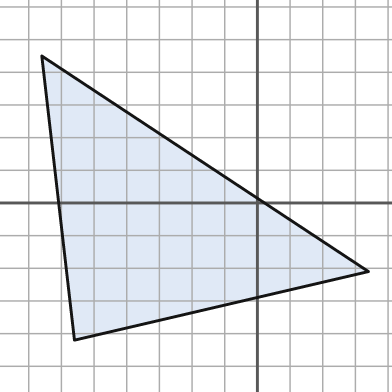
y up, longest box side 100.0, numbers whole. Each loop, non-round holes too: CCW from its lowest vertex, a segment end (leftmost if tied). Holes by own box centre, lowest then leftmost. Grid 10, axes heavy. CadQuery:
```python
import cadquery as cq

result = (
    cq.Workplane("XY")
    .moveTo(-56.0, -42.0)
    .lineTo(34.0, -21.0)
    .lineTo(-66.0, 45.0)
    .close()
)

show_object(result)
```